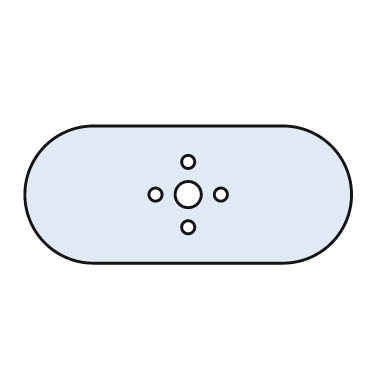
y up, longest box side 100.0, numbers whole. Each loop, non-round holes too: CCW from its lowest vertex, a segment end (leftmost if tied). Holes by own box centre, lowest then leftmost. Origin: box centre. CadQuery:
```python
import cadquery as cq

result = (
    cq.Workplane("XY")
    .moveTo(-29.0, -21.0)
    .lineTo(29.0, -21.0)
    .threePointArc((50.0, 0.0), (29.0, 21.0))
    .lineTo(-29.0, 21.0)
    .threePointArc((-50.0, 0.0), (-29.0, -21.0))
    .close()
    .moveTo(0.0, -10.0)
    .circle(2.0)
    .moveTo(-10.0, 0.0)
    .circle(2.0)
    .moveTo(0.0, 0.0)
    .circle(4.0)
    .moveTo(10.0, 0.0)
    .circle(2.0)
    .moveTo(0.0, 10.0)
    .circle(2.0)
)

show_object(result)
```